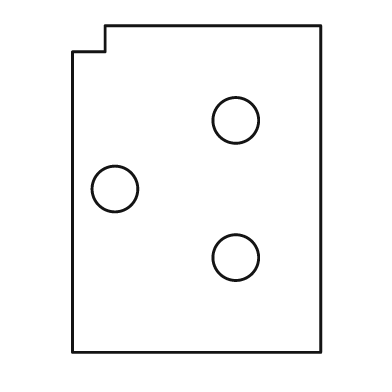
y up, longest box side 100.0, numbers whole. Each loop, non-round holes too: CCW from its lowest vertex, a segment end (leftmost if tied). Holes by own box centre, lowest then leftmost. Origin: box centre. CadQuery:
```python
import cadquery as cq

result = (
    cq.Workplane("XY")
    .moveTo(-38.0, -50.0)
    .lineTo(38.0, -50.0)
    .lineTo(38.0, 50.0)
    .lineTo(-28.0, 50.0)
    .lineTo(-28.0, 42.0)
    .lineTo(-38.0, 42.0)
    .close()
    .moveTo(12.0, -21.0)
    .circle(7.0)
    .moveTo(-25.0, 0.0)
    .circle(7.0)
    .moveTo(12.0, 21.0)
    .circle(7.0)
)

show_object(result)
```